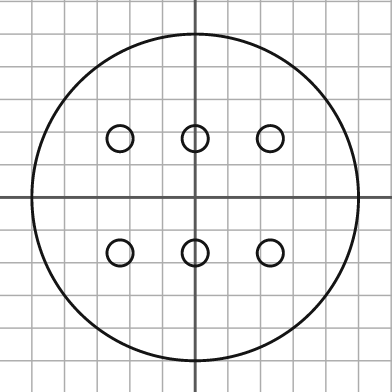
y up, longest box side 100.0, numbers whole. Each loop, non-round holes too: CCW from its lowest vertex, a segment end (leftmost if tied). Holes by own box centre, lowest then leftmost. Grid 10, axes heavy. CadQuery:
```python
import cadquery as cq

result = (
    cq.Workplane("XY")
    .moveTo(0.0, 0.0)
    .circle(50.0)
    .moveTo(-23.0, -17.0)
    .circle(4.0)
    .moveTo(0.0, -17.0)
    .circle(4.0)
    .moveTo(23.0, -17.0)
    .circle(4.0)
    .moveTo(-23.0, 18.0)
    .circle(4.0)
    .moveTo(0.0, 18.0)
    .circle(4.0)
    .moveTo(23.0, 18.0)
    .circle(4.0)
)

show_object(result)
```